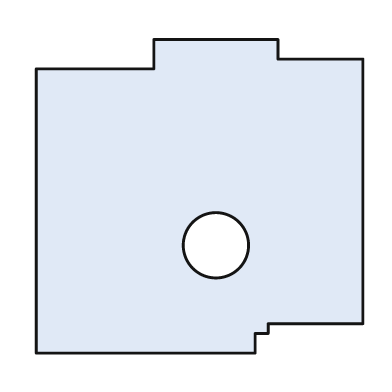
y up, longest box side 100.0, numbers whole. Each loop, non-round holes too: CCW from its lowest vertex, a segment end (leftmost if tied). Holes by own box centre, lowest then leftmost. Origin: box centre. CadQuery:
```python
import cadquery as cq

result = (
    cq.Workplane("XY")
    .moveTo(-50.0, -48.0)
    .lineTo(17.0, -48.0)
    .lineTo(17.0, -42.0)
    .lineTo(21.0, -42.0)
    .lineTo(21.0, -39.0)
    .lineTo(50.0, -39.0)
    .lineTo(50.0, 42.0)
    .lineTo(24.0, 42.0)
    .lineTo(24.0, 48.0)
    .lineTo(-14.0, 48.0)
    .lineTo(-14.0, 39.0)
    .lineTo(-50.0, 39.0)
    .close()
    .moveTo(5.0, -15.0)
    .circle(10.0)
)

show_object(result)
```